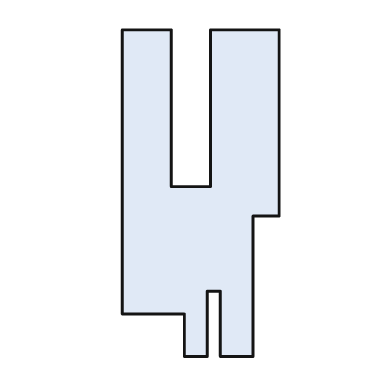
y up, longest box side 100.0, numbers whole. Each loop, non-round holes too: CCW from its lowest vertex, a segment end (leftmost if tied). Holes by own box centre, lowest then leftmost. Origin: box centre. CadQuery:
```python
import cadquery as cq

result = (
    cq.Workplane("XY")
    .moveTo(-5.0, -50.0)
    .lineTo(2.0, -50.0)
    .lineTo(2.0, -30.0)
    .lineTo(6.0, -30.0)
    .lineTo(6.0, -50.0)
    .lineTo(16.0, -50.0)
    .lineTo(16.0, -7.0)
    .lineTo(24.0, -7.0)
    .lineTo(24.0, 50.0)
    .lineTo(3.0, 50.0)
    .lineTo(3.0, 2.0)
    .lineTo(-9.0, 2.0)
    .lineTo(-9.0, 50.0)
    .lineTo(-24.0, 50.0)
    .lineTo(-24.0, -37.0)
    .lineTo(-5.0, -37.0)
    .close()
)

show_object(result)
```